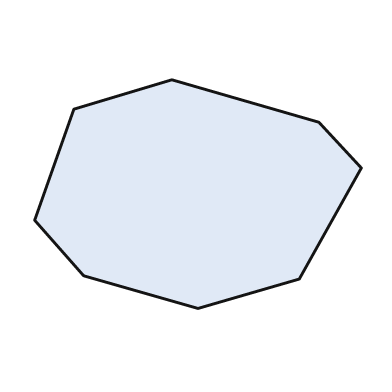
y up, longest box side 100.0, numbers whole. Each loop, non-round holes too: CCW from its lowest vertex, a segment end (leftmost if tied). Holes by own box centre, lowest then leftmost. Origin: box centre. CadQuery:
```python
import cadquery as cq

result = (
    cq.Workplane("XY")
    .moveTo(0.0, -35.0)
    .lineTo(31.0, -26.0)
    .lineTo(50.0, 8.0)
    .lineTo(37.0, 22.0)
    .lineTo(-8.0, 35.0)
    .lineTo(-38.0, 26.0)
    .lineTo(-50.0, -8.0)
    .lineTo(-35.0, -25.0)
    .close()
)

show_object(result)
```